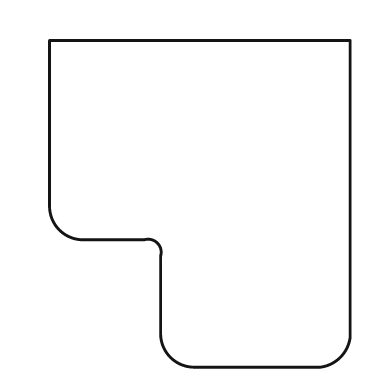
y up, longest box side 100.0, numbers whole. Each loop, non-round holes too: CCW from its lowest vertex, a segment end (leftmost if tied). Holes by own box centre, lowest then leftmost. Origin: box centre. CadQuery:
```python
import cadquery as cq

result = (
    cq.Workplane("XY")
    .moveTo(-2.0, -50.0)
    .lineTo(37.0, -50.0)
    .threePointArc((43.0, -47.0), (46.0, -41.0))
    .lineTo(46.0, 50.0)
    .lineTo(-46.0, 50.0)
    .lineTo(-46.0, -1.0)
    .threePointArc((-43.0, -8.0), (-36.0, -11.0))
    .lineTo(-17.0, -11.0)
    .threePointArc((-13.0, -12.0), (-12.0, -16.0))
    .lineTo(-12.0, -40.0)
    .threePointArc((-9.0, -47.0), (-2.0, -50.0))
    .close()
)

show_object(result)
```